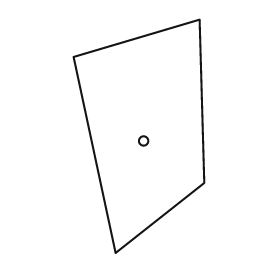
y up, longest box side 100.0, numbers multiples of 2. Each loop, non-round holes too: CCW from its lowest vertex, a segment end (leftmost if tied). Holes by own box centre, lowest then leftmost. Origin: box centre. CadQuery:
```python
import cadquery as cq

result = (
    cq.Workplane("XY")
    .moveTo(-10.0, -50.0)
    .lineTo(28.0, -20.0)
    .lineTo(26.0, 50.0)
    .lineTo(-28.0, 34.0)
    .close()
    .moveTo(2.0, -2.0)
    .circle(2.0)
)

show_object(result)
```